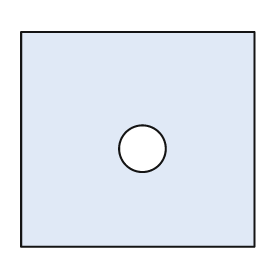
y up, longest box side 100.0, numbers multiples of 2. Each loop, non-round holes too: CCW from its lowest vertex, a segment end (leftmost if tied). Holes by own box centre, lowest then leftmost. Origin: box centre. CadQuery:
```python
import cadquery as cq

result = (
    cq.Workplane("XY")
    .moveTo(-50.0, -46.0)
    .lineTo(50.0, -46.0)
    .lineTo(50.0, 46.0)
    .lineTo(-50.0, 46.0)
    .close()
    .moveTo(2.0, -4.0)
    .circle(10.0)
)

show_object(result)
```